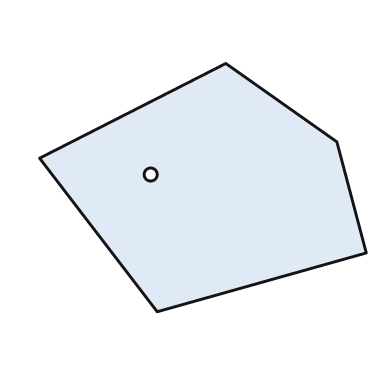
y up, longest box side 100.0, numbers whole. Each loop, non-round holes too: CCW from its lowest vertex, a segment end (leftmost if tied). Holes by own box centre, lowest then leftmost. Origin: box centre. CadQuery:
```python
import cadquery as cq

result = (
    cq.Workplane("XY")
    .moveTo(-14.0, -38.0)
    .lineTo(50.0, -20.0)
    .lineTo(41.0, 14.0)
    .lineTo(7.0, 38.0)
    .lineTo(-50.0, 9.0)
    .close()
    .moveTo(-16.0, 4.0)
    .circle(2.0)
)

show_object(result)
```